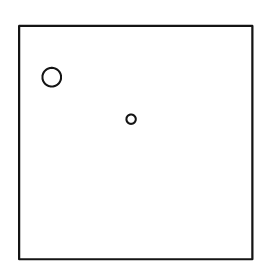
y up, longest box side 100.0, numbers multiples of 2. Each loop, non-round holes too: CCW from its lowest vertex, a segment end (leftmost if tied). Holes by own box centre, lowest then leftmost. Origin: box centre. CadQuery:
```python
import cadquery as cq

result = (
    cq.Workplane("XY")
    .moveTo(-50.0, -50.0)
    .lineTo(50.0, -50.0)
    .lineTo(50.0, 50.0)
    .lineTo(-50.0, 50.0)
    .close()
    .moveTo(-2.0, 10.0)
    .circle(2.0)
    .moveTo(-36.0, 28.0)
    .circle(4.0)
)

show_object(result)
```